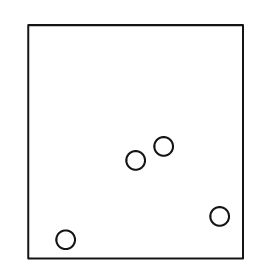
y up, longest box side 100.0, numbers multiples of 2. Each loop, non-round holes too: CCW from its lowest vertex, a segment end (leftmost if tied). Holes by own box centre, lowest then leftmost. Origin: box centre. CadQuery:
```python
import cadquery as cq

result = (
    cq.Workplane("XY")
    .moveTo(-46.0, -50.0)
    .lineTo(46.0, -50.0)
    .lineTo(46.0, 50.0)
    .lineTo(-46.0, 50.0)
    .close()
    .moveTo(-30.0, -42.0)
    .circle(4.0)
    .moveTo(36.0, -32.0)
    .circle(4.0)
    .moveTo(0.0, -8.0)
    .circle(4.0)
    .moveTo(12.0, -2.0)
    .circle(4.0)
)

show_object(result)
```